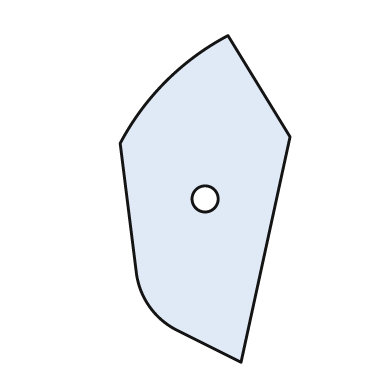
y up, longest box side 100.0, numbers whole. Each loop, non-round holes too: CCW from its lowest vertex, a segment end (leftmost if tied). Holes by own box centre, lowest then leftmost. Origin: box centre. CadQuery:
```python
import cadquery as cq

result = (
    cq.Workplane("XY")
    .moveTo(11.0, -50.0)
    .lineTo(26.0, 19.0)
    .lineTo(7.0, 50.0)
    .threePointArc((-12.0, 36.0), (-26.0, 17.0))
    .lineTo(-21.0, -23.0)
    .threePointArc((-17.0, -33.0), (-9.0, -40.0))
    .close()
    .moveTo(0.0, 0.0)
    .circle(4.0)
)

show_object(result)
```